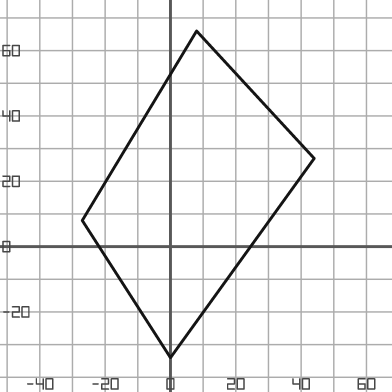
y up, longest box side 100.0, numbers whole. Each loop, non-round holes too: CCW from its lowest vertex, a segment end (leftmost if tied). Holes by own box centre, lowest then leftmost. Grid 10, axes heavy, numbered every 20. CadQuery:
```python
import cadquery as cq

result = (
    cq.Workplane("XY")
    .moveTo(0.0, -34.0)
    .lineTo(44.0, 27.0)
    .lineTo(8.0, 66.0)
    .lineTo(-27.0, 8.0)
    .close()
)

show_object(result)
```